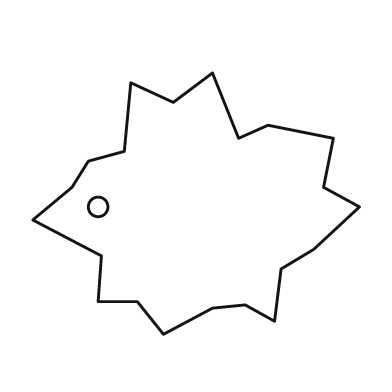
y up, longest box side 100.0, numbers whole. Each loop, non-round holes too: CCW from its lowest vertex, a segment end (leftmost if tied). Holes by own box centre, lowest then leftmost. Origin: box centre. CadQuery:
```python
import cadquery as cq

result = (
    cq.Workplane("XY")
    .moveTo(-10.0, -40.0)
    .lineTo(5.0, -32.0)
    .lineTo(15.0, -31.0)
    .lineTo(24.0, -36.0)
    .lineTo(26.0, -20.0)
    .lineTo(36.0, -14.0)
    .lineTo(50.0, -1.0)
    .lineTo(39.0, 5.0)
    .lineTo(42.0, 20.0)
    .lineTo(22.0, 24.0)
    .lineTo(13.0, 20.0)
    .lineTo(5.0, 40.0)
    .lineTo(-7.0, 31.0)
    .lineTo(-20.0, 37.0)
    .lineTo(-22.0, 16.0)
    .lineTo(-33.0, 13.0)
    .lineTo(-38.0, 5.0)
    .lineTo(-50.0, -5.0)
    .lineTo(-29.0, -16.0)
    .lineTo(-30.0, -30.0)
    .lineTo(-18.0, -30.0)
    .close()
    .moveTo(-30.0, -1.0)
    .circle(3.0)
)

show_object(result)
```